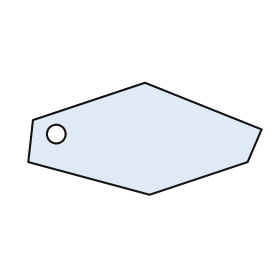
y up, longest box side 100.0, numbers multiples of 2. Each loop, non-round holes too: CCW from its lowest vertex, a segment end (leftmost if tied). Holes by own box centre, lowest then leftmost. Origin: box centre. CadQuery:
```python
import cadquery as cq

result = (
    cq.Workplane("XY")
    .moveTo(2.0, -24.0)
    .lineTo(44.0, -10.0)
    .lineTo(50.0, 4.0)
    .lineTo(0.0, 24.0)
    .lineTo(-48.0, 8.0)
    .lineTo(-50.0, -10.0)
    .close()
    .moveTo(-38.0, 2.0)
    .circle(4.0)
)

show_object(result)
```